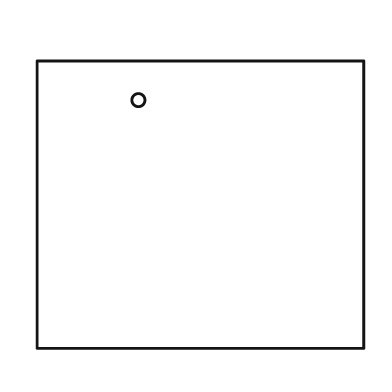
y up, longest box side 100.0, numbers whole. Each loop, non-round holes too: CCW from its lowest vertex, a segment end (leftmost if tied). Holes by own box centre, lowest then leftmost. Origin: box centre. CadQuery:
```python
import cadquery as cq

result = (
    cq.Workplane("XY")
    .moveTo(-50.0, -44.0)
    .lineTo(50.0, -44.0)
    .lineTo(50.0, 44.0)
    .lineTo(-50.0, 44.0)
    .close()
    .moveTo(-19.0, 32.0)
    .circle(2.0)
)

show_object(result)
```